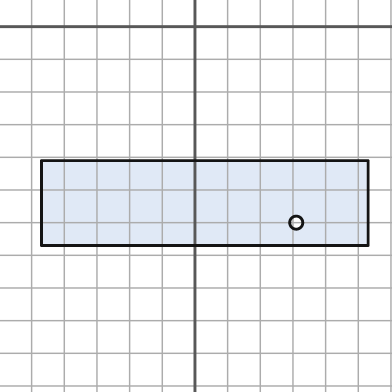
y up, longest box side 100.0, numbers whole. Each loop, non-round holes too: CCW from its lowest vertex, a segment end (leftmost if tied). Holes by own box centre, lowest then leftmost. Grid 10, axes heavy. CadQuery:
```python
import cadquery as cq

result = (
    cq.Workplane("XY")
    .moveTo(-47.0, -67.0)
    .lineTo(53.0, -67.0)
    .lineTo(53.0, -41.0)
    .lineTo(-47.0, -41.0)
    .close()
    .moveTo(31.0, -60.0)
    .circle(2.0)
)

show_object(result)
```